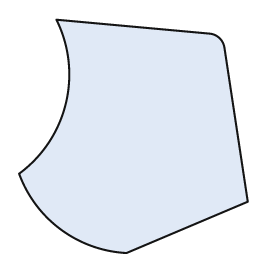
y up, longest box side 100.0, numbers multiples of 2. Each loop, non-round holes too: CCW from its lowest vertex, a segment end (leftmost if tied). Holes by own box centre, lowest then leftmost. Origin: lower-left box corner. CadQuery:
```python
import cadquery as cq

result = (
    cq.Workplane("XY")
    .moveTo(46.0, 0.0)
    .lineTo(98.0, 22.0)
    .lineTo(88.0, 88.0)
    .threePointArc((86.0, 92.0), (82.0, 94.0))
    .lineTo(16.0, 100.0)
    .threePointArc((20.0, 64.0), (0.0, 34.0))
    .threePointArc((18.0, 10.0), (46.0, 0.0))
    .close()
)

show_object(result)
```